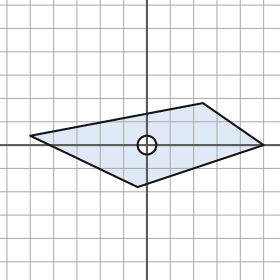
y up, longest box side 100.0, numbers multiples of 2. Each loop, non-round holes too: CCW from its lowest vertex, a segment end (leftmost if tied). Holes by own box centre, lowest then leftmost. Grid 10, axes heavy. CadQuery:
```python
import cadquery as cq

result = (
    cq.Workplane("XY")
    .moveTo(-4.0, -18.0)
    .lineTo(50.0, 0.0)
    .lineTo(24.0, 18.0)
    .lineTo(-50.0, 4.0)
    .close()
    .moveTo(0.0, 0.0)
    .circle(4.0)
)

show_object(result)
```